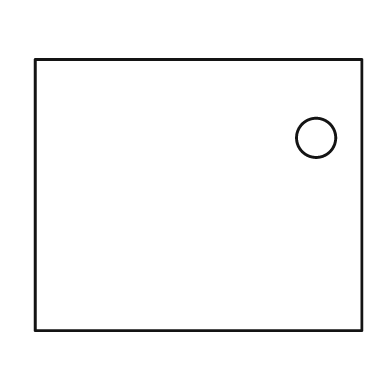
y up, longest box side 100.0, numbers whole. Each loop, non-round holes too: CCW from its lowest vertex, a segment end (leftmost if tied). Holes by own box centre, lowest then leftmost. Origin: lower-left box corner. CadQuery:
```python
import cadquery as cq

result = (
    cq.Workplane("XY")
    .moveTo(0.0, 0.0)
    .lineTo(100.0, 0.0)
    .lineTo(100.0, 83.0)
    .lineTo(0.0, 83.0)
    .close()
    .moveTo(86.0, 59.0)
    .circle(6.0)
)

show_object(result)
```